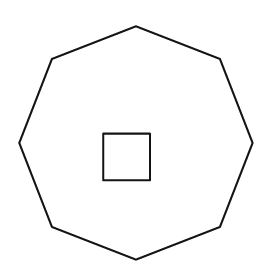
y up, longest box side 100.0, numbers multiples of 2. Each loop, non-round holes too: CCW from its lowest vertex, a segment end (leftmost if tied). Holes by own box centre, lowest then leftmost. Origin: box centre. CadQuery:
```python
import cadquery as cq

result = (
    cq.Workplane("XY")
    .moveTo(0.0, -50.0)
    .lineTo(36.0, -36.0)
    .lineTo(50.0, 0.0)
    .lineTo(36.0, 36.0)
    .lineTo(0.0, 50.0)
    .lineTo(-36.0, 36.0)
    .lineTo(-50.0, 0.0)
    .lineTo(-36.0, -36.0)
    .close()
    .moveTo(-14.0, -16.0)
    .lineTo(6.0, -16.0)
    .lineTo(6.0, 4.0)
    .lineTo(-14.0, 4.0)
    .close()
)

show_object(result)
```